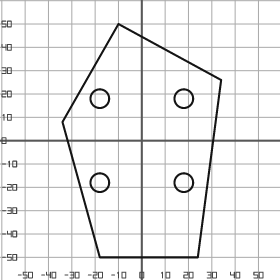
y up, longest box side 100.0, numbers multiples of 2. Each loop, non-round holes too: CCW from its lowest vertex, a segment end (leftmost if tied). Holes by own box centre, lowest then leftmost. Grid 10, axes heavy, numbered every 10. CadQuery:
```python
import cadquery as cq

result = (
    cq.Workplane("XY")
    .moveTo(-18.0, -50.0)
    .lineTo(24.0, -50.0)
    .lineTo(34.0, 26.0)
    .lineTo(-10.0, 50.0)
    .lineTo(-34.0, 8.0)
    .close()
    .moveTo(-18.0, -18.0)
    .circle(4.0)
    .moveTo(18.0, -18.0)
    .circle(4.0)
    .moveTo(-18.0, 18.0)
    .circle(4.0)
    .moveTo(18.0, 18.0)
    .circle(4.0)
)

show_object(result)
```